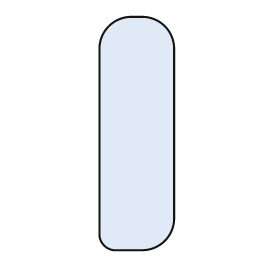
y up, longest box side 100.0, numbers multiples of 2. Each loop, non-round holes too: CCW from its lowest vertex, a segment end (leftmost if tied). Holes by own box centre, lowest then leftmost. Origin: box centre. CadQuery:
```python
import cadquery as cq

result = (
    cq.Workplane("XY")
    .moveTo(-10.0, -50.0)
    .lineTo(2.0, -50.0)
    .threePointArc((12.0, -46.0), (16.0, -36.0))
    .lineTo(16.0, 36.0)
    .threePointArc((12.0, 46.0), (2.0, 50.0))
    .lineTo(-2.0, 50.0)
    .threePointArc((-12.0, 46.0), (-16.0, 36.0))
    .lineTo(-16.0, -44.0)
    .threePointArc((-14.0, -48.0), (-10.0, -50.0))
    .close()
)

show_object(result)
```